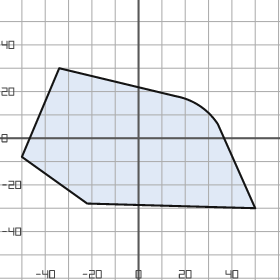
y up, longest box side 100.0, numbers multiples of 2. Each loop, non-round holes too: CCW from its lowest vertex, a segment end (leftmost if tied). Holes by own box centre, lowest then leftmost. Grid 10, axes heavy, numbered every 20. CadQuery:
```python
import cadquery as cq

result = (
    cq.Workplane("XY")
    .moveTo(50.0, -30.0)
    .lineTo(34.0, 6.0)
    .threePointArc((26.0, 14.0), (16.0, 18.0))
    .lineTo(-34.0, 30.0)
    .lineTo(-50.0, -8.0)
    .lineTo(-22.0, -28.0)
    .close()
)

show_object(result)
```